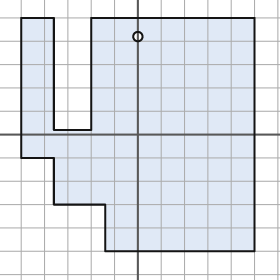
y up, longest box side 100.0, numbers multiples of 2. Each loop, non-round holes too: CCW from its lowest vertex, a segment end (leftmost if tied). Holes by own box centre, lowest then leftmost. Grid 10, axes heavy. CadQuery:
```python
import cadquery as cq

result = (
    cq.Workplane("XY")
    .moveTo(-14.0, -50.0)
    .lineTo(50.0, -50.0)
    .lineTo(50.0, 50.0)
    .lineTo(-20.0, 50.0)
    .lineTo(-20.0, 2.0)
    .lineTo(-36.0, 2.0)
    .lineTo(-36.0, 50.0)
    .lineTo(-50.0, 50.0)
    .lineTo(-50.0, -10.0)
    .lineTo(-36.0, -10.0)
    .lineTo(-36.0, -30.0)
    .lineTo(-14.0, -30.0)
    .close()
    .moveTo(0.0, 42.0)
    .circle(2.0)
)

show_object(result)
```